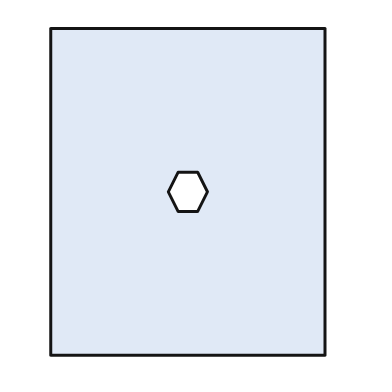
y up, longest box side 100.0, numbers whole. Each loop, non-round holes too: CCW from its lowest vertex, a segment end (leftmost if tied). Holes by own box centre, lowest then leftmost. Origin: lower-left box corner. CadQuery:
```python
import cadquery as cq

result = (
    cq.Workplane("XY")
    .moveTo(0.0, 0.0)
    .lineTo(84.0, 0.0)
    .lineTo(84.0, 100.0)
    .lineTo(0.0, 100.0)
    .close()
    .moveTo(39.0, 44.0)
    .lineTo(45.0, 44.0)
    .lineTo(48.0, 50.0)
    .lineTo(45.0, 56.0)
    .lineTo(39.0, 56.0)
    .lineTo(36.0, 50.0)
    .close()
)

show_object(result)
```